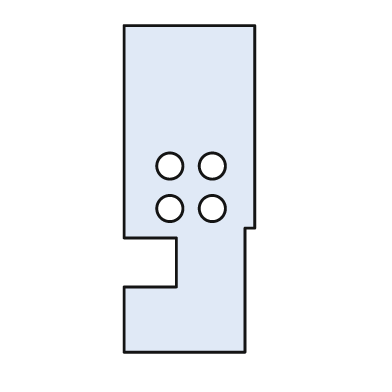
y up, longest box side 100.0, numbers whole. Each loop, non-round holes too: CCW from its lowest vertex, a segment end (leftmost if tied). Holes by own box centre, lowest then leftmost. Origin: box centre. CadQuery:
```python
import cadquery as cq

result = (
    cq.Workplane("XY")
    .moveTo(-20.0, -50.0)
    .lineTo(17.0, -50.0)
    .lineTo(17.0, -12.0)
    .lineTo(20.0, -12.0)
    .lineTo(20.0, 50.0)
    .lineTo(-20.0, 50.0)
    .lineTo(-20.0, -15.0)
    .lineTo(-4.0, -15.0)
    .lineTo(-4.0, -30.0)
    .lineTo(-20.0, -30.0)
    .close()
    .moveTo(-6.0, -6.0)
    .circle(4.0)
    .moveTo(7.0, -6.0)
    .circle(4.0)
    .moveTo(-6.0, 7.0)
    .circle(4.0)
    .moveTo(7.0, 7.0)
    .circle(4.0)
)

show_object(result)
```